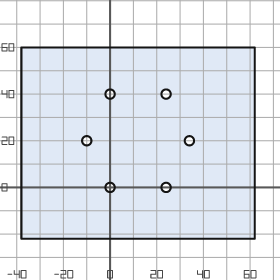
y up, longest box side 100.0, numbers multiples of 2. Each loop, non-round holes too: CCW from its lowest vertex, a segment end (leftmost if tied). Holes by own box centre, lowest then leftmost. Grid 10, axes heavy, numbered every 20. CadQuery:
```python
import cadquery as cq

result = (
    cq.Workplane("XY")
    .moveTo(-38.0, -22.0)
    .lineTo(62.0, -22.0)
    .lineTo(62.0, 60.0)
    .lineTo(-38.0, 60.0)
    .close()
    .moveTo(0.0, 0.0)
    .circle(2.0)
    .moveTo(24.0, 0.0)
    .circle(2.0)
    .moveTo(-10.0, 20.0)
    .circle(2.0)
    .moveTo(34.0, 20.0)
    .circle(2.0)
    .moveTo(0.0, 40.0)
    .circle(2.0)
    .moveTo(24.0, 40.0)
    .circle(2.0)
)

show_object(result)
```